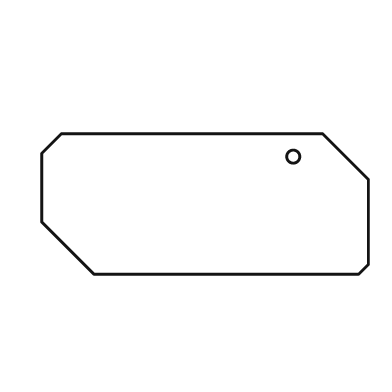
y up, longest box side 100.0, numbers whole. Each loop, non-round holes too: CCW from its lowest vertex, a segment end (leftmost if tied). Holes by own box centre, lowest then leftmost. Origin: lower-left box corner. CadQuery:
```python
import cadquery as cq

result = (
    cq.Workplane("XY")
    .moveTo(16.0, 0.0)
    .lineTo(97.0, 0.0)
    .lineTo(100.0, 3.0)
    .lineTo(100.0, 29.0)
    .lineTo(86.0, 43.0)
    .lineTo(6.0, 43.0)
    .lineTo(0.0, 37.0)
    .lineTo(0.0, 16.0)
    .close()
    .moveTo(77.0, 36.0)
    .circle(2.0)
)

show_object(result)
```